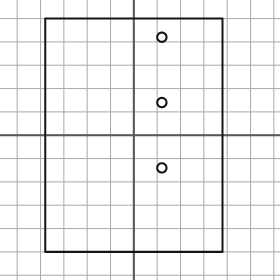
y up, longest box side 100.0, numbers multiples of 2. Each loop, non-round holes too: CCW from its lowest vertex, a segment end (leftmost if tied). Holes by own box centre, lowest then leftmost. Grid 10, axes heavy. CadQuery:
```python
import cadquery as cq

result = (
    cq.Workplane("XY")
    .moveTo(-38.0, -50.0)
    .lineTo(38.0, -50.0)
    .lineTo(38.0, 50.0)
    .lineTo(-38.0, 50.0)
    .close()
    .moveTo(12.0, -14.0)
    .circle(2.0)
    .moveTo(12.0, 14.0)
    .circle(2.0)
    .moveTo(12.0, 42.0)
    .circle(2.0)
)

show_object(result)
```